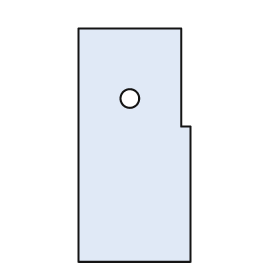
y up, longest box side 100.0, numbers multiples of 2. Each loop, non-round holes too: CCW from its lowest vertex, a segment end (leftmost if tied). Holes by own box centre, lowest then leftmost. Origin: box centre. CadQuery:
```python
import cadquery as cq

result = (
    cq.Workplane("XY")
    .moveTo(-24.0, -50.0)
    .lineTo(24.0, -50.0)
    .lineTo(24.0, 8.0)
    .lineTo(20.0, 8.0)
    .lineTo(20.0, 50.0)
    .lineTo(-24.0, 50.0)
    .close()
    .moveTo(-2.0, 20.0)
    .circle(4.0)
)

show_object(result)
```